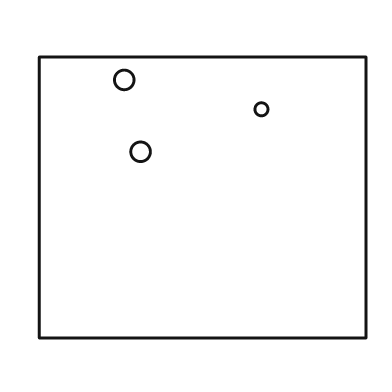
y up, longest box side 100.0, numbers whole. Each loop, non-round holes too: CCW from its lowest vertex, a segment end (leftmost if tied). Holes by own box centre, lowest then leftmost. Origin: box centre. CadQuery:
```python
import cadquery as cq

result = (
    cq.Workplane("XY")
    .moveTo(-50.0, -43.0)
    .lineTo(50.0, -43.0)
    .lineTo(50.0, 43.0)
    .lineTo(-50.0, 43.0)
    .close()
    .moveTo(-19.0, 14.0)
    .circle(3.0)
    .moveTo(18.0, 27.0)
    .circle(2.0)
    .moveTo(-24.0, 36.0)
    .circle(3.0)
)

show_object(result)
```